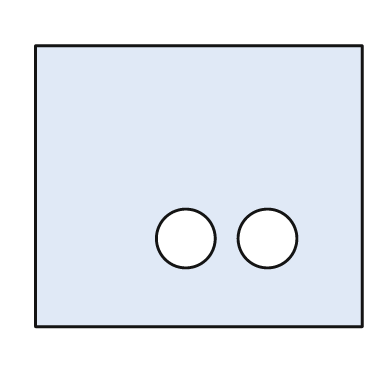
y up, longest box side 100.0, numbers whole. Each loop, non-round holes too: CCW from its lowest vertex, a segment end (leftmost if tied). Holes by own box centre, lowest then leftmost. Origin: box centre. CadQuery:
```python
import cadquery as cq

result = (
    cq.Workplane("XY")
    .moveTo(-50.0, -43.0)
    .lineTo(50.0, -43.0)
    .lineTo(50.0, 43.0)
    .lineTo(-50.0, 43.0)
    .close()
    .moveTo(-4.0, -16.0)
    .circle(9.0)
    .moveTo(21.0, -16.0)
    .circle(9.0)
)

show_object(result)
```